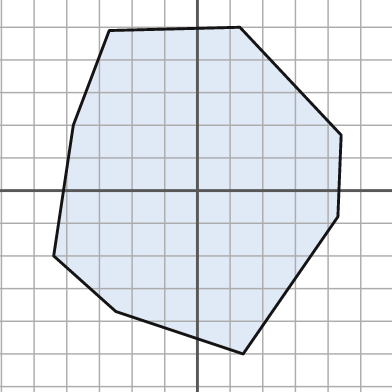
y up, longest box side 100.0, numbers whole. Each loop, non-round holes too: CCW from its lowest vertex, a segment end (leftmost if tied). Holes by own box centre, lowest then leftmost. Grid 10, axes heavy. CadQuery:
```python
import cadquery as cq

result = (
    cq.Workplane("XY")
    .moveTo(14.0, -50.0)
    .lineTo(43.0, -8.0)
    .lineTo(44.0, 17.0)
    .lineTo(13.0, 50.0)
    .lineTo(-27.0, 49.0)
    .lineTo(-38.0, 20.0)
    .lineTo(-44.0, -20.0)
    .lineTo(-25.0, -37.0)
    .close()
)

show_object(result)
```